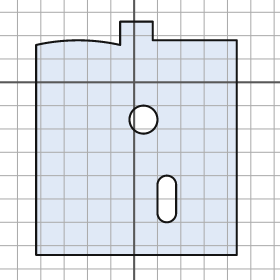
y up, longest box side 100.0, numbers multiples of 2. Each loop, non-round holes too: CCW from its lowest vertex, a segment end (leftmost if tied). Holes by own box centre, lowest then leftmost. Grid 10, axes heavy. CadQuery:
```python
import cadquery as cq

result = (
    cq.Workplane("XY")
    .moveTo(-42.0, -74.0)
    .lineTo(44.0, -74.0)
    .lineTo(44.0, 18.0)
    .lineTo(8.0, 18.0)
    .lineTo(8.0, 26.0)
    .lineTo(-6.0, 26.0)
    .lineTo(-6.0, 16.0)
    .threePointArc((-24.0, 18.0), (-42.0, 16.0))
    .close()
    .moveTo(10.0, -56.0)
    .threePointArc((14.0, -60.0), (18.0, -56.0))
    .lineTo(18.0, -44.0)
    .threePointArc((14.0, -40.0), (10.0, -44.0))
    .close()
    .moveTo(4.0, -16.0)
    .circle(6.0)
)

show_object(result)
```